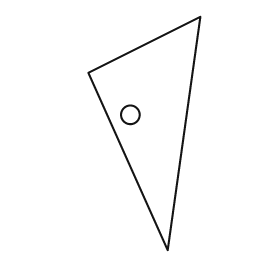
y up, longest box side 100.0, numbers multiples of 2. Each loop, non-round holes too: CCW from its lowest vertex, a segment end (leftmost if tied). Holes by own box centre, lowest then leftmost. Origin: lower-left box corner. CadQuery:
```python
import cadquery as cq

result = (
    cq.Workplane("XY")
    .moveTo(34.0, 0.0)
    .lineTo(48.0, 100.0)
    .lineTo(0.0, 76.0)
    .close()
    .moveTo(18.0, 58.0)
    .circle(4.0)
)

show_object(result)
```